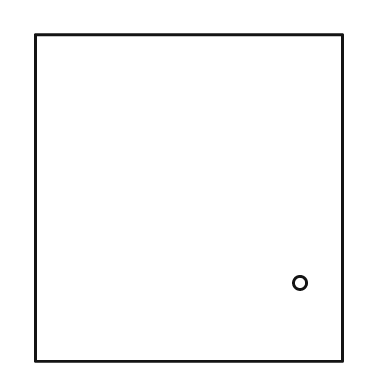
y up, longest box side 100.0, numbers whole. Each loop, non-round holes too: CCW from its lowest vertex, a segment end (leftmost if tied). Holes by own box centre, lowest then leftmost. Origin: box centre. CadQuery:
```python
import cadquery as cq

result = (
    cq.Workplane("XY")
    .moveTo(-47.0, -50.0)
    .lineTo(47.0, -50.0)
    .lineTo(47.0, 50.0)
    .lineTo(-47.0, 50.0)
    .close()
    .moveTo(34.0, -26.0)
    .circle(2.0)
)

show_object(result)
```